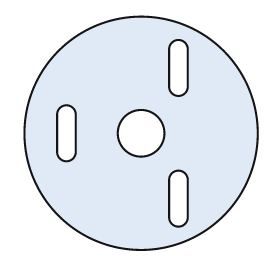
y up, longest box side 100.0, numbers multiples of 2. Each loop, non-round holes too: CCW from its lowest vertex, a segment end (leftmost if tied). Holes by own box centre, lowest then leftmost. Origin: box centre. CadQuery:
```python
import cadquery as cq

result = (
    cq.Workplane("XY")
    .moveTo(0.0, 0.0)
    .circle(50.0)
    .moveTo(12.0, -36.0)
    .threePointArc((16.0, -40.0), (20.0, -36.0))
    .lineTo(20.0, -20.0)
    .threePointArc((16.0, -16.0), (12.0, -20.0))
    .close()
    .moveTo(-36.0, -8.0)
    .threePointArc((-32.0, -12.0), (-28.0, -8.0))
    .lineTo(-28.0, 8.0)
    .threePointArc((-32.0, 12.0), (-36.0, 8.0))
    .close()
    .moveTo(0.0, 0.0)
    .circle(10.0)
    .moveTo(12.0, 20.0)
    .threePointArc((16.0, 16.0), (20.0, 20.0))
    .lineTo(20.0, 36.0)
    .threePointArc((16.0, 40.0), (12.0, 36.0))
    .close()
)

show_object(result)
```